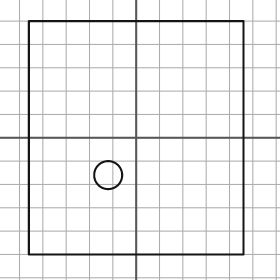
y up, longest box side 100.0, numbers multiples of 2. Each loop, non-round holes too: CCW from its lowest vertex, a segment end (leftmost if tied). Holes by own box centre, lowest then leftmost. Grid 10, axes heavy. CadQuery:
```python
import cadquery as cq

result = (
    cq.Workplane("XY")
    .moveTo(-46.0, -50.0)
    .lineTo(46.0, -50.0)
    .lineTo(46.0, 50.0)
    .lineTo(-46.0, 50.0)
    .close()
    .moveTo(-12.0, -16.0)
    .circle(6.0)
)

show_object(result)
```